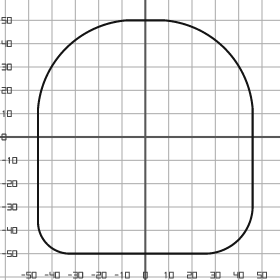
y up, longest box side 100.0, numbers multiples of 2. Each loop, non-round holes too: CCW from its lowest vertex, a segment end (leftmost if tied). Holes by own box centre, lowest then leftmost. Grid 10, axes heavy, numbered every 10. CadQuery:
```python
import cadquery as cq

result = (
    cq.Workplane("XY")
    .moveTo(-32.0, -50.0)
    .lineTo(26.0, -50.0)
    .threePointArc((40.0, -44.0), (46.0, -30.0))
    .lineTo(46.0, 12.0)
    .threePointArc((34.0, 38.0), (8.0, 50.0))
    .lineTo(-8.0, 50.0)
    .threePointArc((-34.0, 38.0), (-46.0, 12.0))
    .lineTo(-46.0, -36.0)
    .threePointArc((-42.0, -46.0), (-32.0, -50.0))
    .close()
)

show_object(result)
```